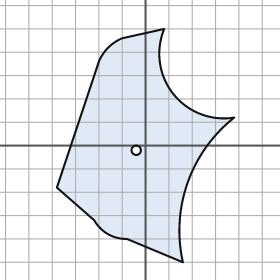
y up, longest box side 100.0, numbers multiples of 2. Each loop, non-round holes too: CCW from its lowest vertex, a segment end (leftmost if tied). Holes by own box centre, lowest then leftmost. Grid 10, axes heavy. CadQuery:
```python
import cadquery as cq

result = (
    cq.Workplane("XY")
    .moveTo(16.0, -50.0)
    .threePointArc((18.0, -16.0), (38.0, 12.0))
    .threePointArc((12.0, 22.0), (8.0, 50.0))
    .lineTo(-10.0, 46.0)
    .threePointArc((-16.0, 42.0), (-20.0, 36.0))
    .lineTo(-38.0, -18.0)
    .lineTo(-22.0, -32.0)
    .threePointArc((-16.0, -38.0), (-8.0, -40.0))
    .close()
    .moveTo(-4.0, -2.0)
    .circle(2.0)
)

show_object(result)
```